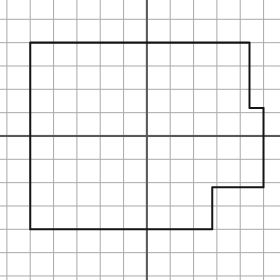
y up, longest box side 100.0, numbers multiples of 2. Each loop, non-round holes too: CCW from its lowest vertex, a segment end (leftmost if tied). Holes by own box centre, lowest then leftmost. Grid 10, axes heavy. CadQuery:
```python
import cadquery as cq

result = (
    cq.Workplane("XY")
    .moveTo(-50.0, -40.0)
    .lineTo(28.0, -40.0)
    .lineTo(28.0, -22.0)
    .lineTo(50.0, -22.0)
    .lineTo(50.0, 12.0)
    .lineTo(44.0, 12.0)
    .lineTo(44.0, 40.0)
    .lineTo(-50.0, 40.0)
    .close()
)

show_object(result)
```